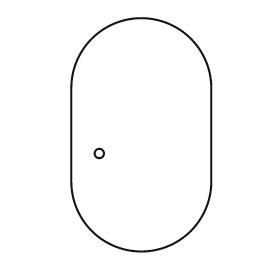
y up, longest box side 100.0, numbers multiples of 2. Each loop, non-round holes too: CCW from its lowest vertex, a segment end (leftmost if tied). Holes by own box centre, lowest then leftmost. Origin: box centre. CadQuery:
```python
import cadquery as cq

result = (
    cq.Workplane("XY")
    .moveTo(-30.0, -20.0)
    .threePointArc((0.0, -50.0), (30.0, -20.0))
    .lineTo(30.0, 20.0)
    .threePointArc((0.0, 50.0), (-30.0, 20.0))
    .close()
    .moveTo(-18.0, -8.0)
    .circle(2.0)
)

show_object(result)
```